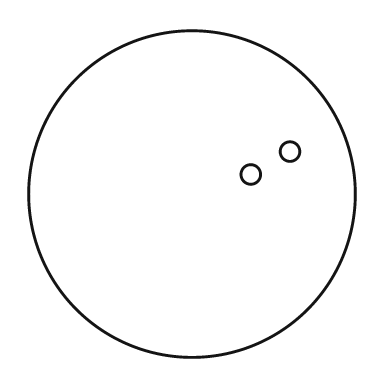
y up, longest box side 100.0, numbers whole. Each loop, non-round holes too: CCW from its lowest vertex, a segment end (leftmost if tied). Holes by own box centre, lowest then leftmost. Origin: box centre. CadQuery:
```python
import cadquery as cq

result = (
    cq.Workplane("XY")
    .moveTo(0.0, 0.0)
    .circle(50.0)
    .moveTo(18.0, 6.0)
    .circle(3.0)
    .moveTo(30.0, 13.0)
    .circle(3.0)
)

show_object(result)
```